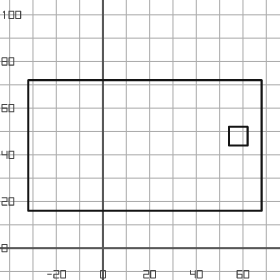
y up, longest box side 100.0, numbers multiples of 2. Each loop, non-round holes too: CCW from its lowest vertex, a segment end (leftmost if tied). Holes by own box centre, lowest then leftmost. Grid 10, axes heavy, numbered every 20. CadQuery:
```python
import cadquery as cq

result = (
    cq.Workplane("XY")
    .moveTo(-32.0, 16.0)
    .lineTo(68.0, 16.0)
    .lineTo(68.0, 72.0)
    .lineTo(-32.0, 72.0)
    .close()
    .moveTo(54.0, 44.0)
    .lineTo(62.0, 44.0)
    .lineTo(62.0, 52.0)
    .lineTo(54.0, 52.0)
    .close()
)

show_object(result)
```